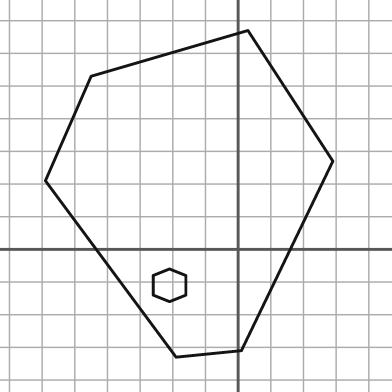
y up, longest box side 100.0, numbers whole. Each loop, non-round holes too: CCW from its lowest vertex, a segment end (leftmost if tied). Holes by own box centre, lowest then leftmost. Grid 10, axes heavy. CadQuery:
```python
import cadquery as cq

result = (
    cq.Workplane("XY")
    .moveTo(-19.0, -33.0)
    .lineTo(1.0, -31.0)
    .lineTo(29.0, 27.0)
    .lineTo(3.0, 67.0)
    .lineTo(-45.0, 53.0)
    .lineTo(-59.0, 21.0)
    .close()
    .moveTo(-21.0, -16.0)
    .lineTo(-16.0, -14.0)
    .lineTo(-16.0, -8.0)
    .lineTo(-21.0, -6.0)
    .lineTo(-26.0, -8.0)
    .lineTo(-26.0, -14.0)
    .close()
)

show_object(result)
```